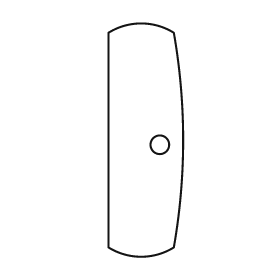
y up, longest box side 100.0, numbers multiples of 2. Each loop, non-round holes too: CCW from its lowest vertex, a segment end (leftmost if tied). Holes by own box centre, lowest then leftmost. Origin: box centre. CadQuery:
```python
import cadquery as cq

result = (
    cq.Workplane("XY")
    .moveTo(-16.0, -46.0)
    .threePointArc((-2.0, -50.0), (12.0, -46.0))
    .threePointArc((16.0, 0.0), (12.0, 46.0))
    .threePointArc((-2.0, 50.0), (-16.0, 46.0))
    .close()
    .moveTo(6.0, -2.0)
    .circle(4.0)
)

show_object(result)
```